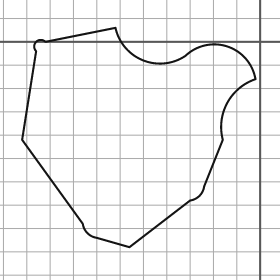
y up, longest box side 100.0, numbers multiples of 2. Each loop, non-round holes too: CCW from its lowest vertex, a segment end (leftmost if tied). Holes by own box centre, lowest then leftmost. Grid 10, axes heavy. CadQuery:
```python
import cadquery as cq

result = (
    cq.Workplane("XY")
    .moveTo(-56.0, -88.0)
    .lineTo(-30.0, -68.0)
    .threePointArc((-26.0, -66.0), (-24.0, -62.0))
    .lineTo(-16.0, -42.0)
    .threePointArc((-14.0, -26.0), (-2.0, -16.0))
    .threePointArc((-14.0, -2.0), (-32.0, -6.0))
    .threePointArc((-50.0, -8.0), (-62.0, 6.0))
    .lineTo(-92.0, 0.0)
    .threePointArc((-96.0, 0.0), (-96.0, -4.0))
    .lineTo(-102.0, -42.0)
    .lineTo(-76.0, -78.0)
    .threePointArc((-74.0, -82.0), (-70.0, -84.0))
    .close()
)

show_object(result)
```